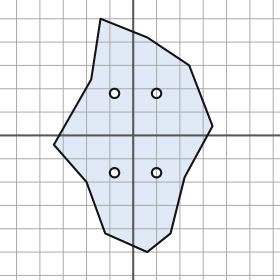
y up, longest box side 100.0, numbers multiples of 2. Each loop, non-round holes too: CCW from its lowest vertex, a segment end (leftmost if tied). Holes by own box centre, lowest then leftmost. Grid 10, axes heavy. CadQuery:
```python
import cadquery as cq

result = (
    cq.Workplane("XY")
    .moveTo(6.0, -50.0)
    .lineTo(16.0, -42.0)
    .lineTo(22.0, -18.0)
    .lineTo(34.0, 4.0)
    .lineTo(24.0, 30.0)
    .lineTo(6.0, 42.0)
    .lineTo(-14.0, 50.0)
    .lineTo(-18.0, 24.0)
    .lineTo(-34.0, -4.0)
    .lineTo(-20.0, -20.0)
    .lineTo(-12.0, -42.0)
    .close()
    .moveTo(-8.0, -16.0)
    .circle(2.0)
    .moveTo(10.0, -16.0)
    .circle(2.0)
    .moveTo(-8.0, 18.0)
    .circle(2.0)
    .moveTo(10.0, 18.0)
    .circle(2.0)
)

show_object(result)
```